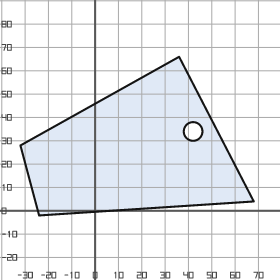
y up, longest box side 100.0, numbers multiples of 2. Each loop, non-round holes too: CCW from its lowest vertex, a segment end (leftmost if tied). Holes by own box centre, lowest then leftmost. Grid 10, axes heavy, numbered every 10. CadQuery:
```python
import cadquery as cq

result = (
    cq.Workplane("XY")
    .moveTo(-24.0, -2.0)
    .lineTo(68.0, 4.0)
    .lineTo(36.0, 66.0)
    .lineTo(-32.0, 28.0)
    .close()
    .moveTo(42.0, 34.0)
    .circle(4.0)
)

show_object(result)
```